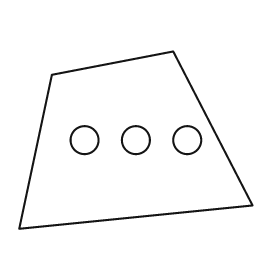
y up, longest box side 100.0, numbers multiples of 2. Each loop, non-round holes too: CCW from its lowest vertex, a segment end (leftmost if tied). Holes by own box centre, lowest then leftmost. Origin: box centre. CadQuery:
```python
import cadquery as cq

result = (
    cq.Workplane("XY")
    .moveTo(-50.0, -38.0)
    .lineTo(50.0, -28.0)
    .lineTo(16.0, 38.0)
    .lineTo(-36.0, 28.0)
    .close()
    .moveTo(-22.0, 0.0)
    .circle(6.0)
    .moveTo(0.0, 0.0)
    .circle(6.0)
    .moveTo(22.0, 0.0)
    .circle(6.0)
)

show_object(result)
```